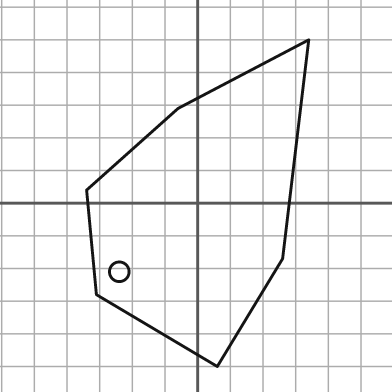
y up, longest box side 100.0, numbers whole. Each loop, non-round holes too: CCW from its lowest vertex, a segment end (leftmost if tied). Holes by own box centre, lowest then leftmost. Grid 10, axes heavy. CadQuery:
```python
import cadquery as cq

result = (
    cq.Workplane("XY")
    .moveTo(6.0, -50.0)
    .lineTo(26.0, -17.0)
    .lineTo(34.0, 50.0)
    .lineTo(-6.0, 29.0)
    .lineTo(-34.0, 4.0)
    .lineTo(-31.0, -28.0)
    .close()
    .moveTo(-24.0, -21.0)
    .circle(3.0)
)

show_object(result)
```